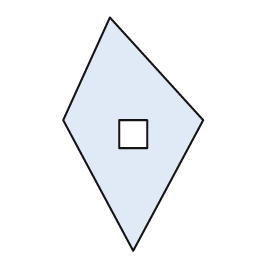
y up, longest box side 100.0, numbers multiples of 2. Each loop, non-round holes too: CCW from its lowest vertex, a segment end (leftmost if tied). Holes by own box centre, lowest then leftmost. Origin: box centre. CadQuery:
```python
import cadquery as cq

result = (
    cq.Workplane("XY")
    .moveTo(0.0, -50.0)
    .lineTo(30.0, 6.0)
    .lineTo(-10.0, 50.0)
    .lineTo(-30.0, 6.0)
    .close()
    .moveTo(-6.0, -6.0)
    .lineTo(6.0, -6.0)
    .lineTo(6.0, 6.0)
    .lineTo(-6.0, 6.0)
    .close()
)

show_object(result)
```